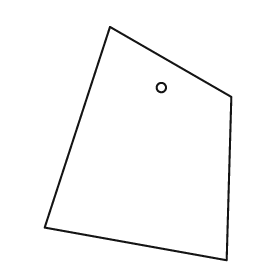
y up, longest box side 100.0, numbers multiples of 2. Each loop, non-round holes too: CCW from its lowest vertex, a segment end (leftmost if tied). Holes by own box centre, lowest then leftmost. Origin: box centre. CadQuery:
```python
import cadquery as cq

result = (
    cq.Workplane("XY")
    .moveTo(38.0, -50.0)
    .lineTo(40.0, 20.0)
    .lineTo(-12.0, 50.0)
    .lineTo(-40.0, -36.0)
    .close()
    .moveTo(10.0, 24.0)
    .circle(2.0)
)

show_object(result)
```